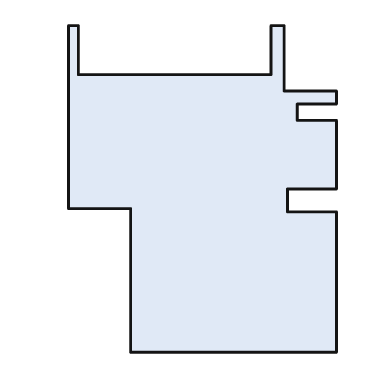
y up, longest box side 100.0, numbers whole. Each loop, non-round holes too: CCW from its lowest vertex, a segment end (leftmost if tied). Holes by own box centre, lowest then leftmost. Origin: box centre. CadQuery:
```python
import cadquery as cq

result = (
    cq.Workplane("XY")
    .moveTo(-22.0, -50.0)
    .lineTo(41.0, -50.0)
    .lineTo(41.0, -7.0)
    .lineTo(26.0, -7.0)
    .lineTo(26.0, 0.0)
    .lineTo(41.0, 0.0)
    .lineTo(41.0, 21.0)
    .lineTo(29.0, 21.0)
    .lineTo(29.0, 26.0)
    .lineTo(41.0, 26.0)
    .lineTo(41.0, 30.0)
    .lineTo(25.0, 30.0)
    .lineTo(25.0, 50.0)
    .lineTo(21.0, 50.0)
    .lineTo(21.0, 35.0)
    .lineTo(-38.0, 35.0)
    .lineTo(-38.0, 50.0)
    .lineTo(-41.0, 50.0)
    .lineTo(-41.0, -6.0)
    .lineTo(-22.0, -6.0)
    .close()
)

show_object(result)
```